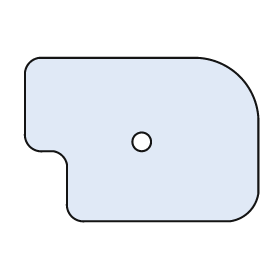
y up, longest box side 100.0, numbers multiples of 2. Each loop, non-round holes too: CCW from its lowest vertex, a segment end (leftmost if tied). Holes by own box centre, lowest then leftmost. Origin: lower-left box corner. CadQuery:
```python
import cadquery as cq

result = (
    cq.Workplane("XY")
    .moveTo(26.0, 0.0)
    .lineTo(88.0, 0.0)
    .threePointArc((96.0, 4.0), (100.0, 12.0))
    .lineTo(100.0, 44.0)
    .threePointArc((92.0, 62.0), (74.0, 70.0))
    .lineTo(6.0, 70.0)
    .threePointArc((2.0, 68.0), (0.0, 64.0))
    .lineTo(0.0, 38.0)
    .threePointArc((2.0, 32.0), (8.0, 30.0))
    .lineTo(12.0, 30.0)
    .threePointArc((16.0, 28.0), (18.0, 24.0))
    .lineTo(18.0, 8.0)
    .threePointArc((20.0, 2.0), (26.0, 0.0))
    .close()
    .moveTo(50.0, 34.0)
    .circle(4.0)
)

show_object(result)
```